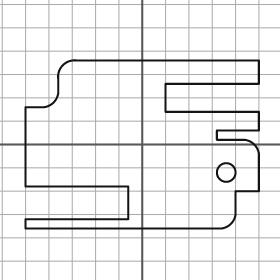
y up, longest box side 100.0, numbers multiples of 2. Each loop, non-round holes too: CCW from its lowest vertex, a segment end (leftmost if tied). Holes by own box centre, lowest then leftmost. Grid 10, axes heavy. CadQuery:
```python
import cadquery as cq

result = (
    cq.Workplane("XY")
    .moveTo(-50.0, -36.0)
    .lineTo(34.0, -36.0)
    .threePointArc((38.0, -34.0), (40.0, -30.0))
    .lineTo(40.0, -20.0)
    .lineTo(50.0, -20.0)
    .lineTo(50.0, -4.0)
    .threePointArc((48.0, 0.0), (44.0, 2.0))
    .lineTo(32.0, 2.0)
    .lineTo(32.0, 6.0)
    .lineTo(50.0, 6.0)
    .lineTo(50.0, 14.0)
    .lineTo(10.0, 14.0)
    .lineTo(10.0, 26.0)
    .lineTo(50.0, 26.0)
    .lineTo(50.0, 36.0)
    .lineTo(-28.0, 36.0)
    .threePointArc((-34.0, 34.0), (-36.0, 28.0))
    .lineTo(-36.0, 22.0)
    .threePointArc((-38.0, 18.0), (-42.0, 16.0))
    .lineTo(-50.0, 16.0)
    .lineTo(-50.0, -18.0)
    .lineTo(-6.0, -18.0)
    .lineTo(-6.0, -32.0)
    .lineTo(-50.0, -32.0)
    .close()
    .moveTo(36.0, -12.0)
    .circle(4.0)
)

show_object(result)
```